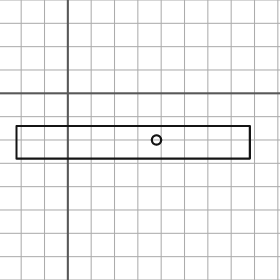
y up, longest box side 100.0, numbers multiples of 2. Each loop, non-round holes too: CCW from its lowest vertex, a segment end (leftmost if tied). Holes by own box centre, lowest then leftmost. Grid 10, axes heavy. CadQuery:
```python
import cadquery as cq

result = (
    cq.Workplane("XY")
    .moveTo(-22.0, -28.0)
    .lineTo(78.0, -28.0)
    .lineTo(78.0, -14.0)
    .lineTo(-22.0, -14.0)
    .close()
    .moveTo(38.0, -20.0)
    .circle(2.0)
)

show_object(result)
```